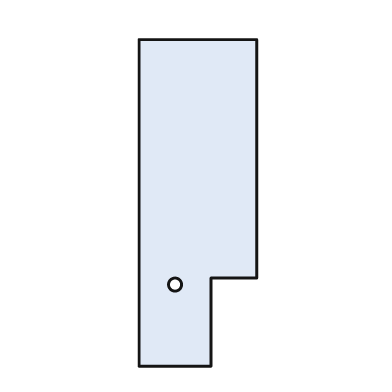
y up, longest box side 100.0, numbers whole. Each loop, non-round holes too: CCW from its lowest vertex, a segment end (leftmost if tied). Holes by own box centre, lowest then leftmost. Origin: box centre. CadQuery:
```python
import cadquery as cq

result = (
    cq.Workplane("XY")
    .moveTo(-18.0, -50.0)
    .lineTo(4.0, -50.0)
    .lineTo(4.0, -23.0)
    .lineTo(18.0, -23.0)
    .lineTo(18.0, 50.0)
    .lineTo(-18.0, 50.0)
    .close()
    .moveTo(-7.0, -25.0)
    .circle(2.0)
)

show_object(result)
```